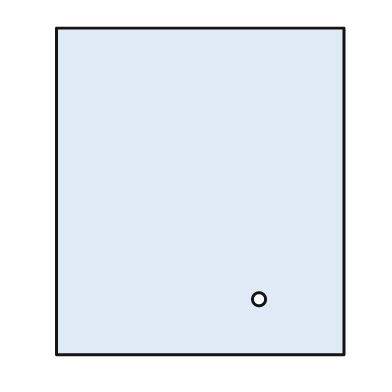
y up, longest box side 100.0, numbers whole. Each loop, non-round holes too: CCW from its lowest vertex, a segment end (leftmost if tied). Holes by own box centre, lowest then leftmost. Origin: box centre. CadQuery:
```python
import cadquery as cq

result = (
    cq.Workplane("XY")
    .moveTo(-44.0, -50.0)
    .lineTo(44.0, -50.0)
    .lineTo(44.0, 50.0)
    .lineTo(-44.0, 50.0)
    .close()
    .moveTo(18.0, -33.0)
    .circle(2.0)
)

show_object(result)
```